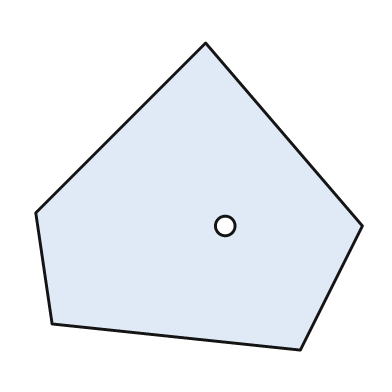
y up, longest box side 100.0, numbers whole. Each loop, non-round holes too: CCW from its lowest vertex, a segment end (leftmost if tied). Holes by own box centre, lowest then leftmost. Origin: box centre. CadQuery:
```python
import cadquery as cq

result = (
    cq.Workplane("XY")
    .moveTo(31.0, -47.0)
    .lineTo(50.0, -9.0)
    .lineTo(2.0, 47.0)
    .lineTo(-50.0, -5.0)
    .lineTo(-45.0, -39.0)
    .close()
    .moveTo(8.0, -9.0)
    .circle(3.0)
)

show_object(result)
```